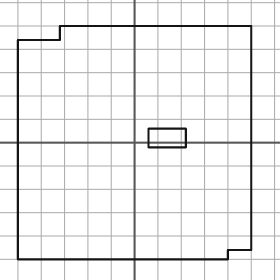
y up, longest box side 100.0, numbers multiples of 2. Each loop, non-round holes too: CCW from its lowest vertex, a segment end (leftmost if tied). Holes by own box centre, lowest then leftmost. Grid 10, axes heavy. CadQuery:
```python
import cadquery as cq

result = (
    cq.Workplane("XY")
    .moveTo(-50.0, -50.0)
    .lineTo(40.0, -50.0)
    .lineTo(40.0, -46.0)
    .lineTo(50.0, -46.0)
    .lineTo(50.0, 50.0)
    .lineTo(-32.0, 50.0)
    .lineTo(-32.0, 44.0)
    .lineTo(-50.0, 44.0)
    .close()
    .moveTo(6.0, -2.0)
    .lineTo(22.0, -2.0)
    .lineTo(22.0, 6.0)
    .lineTo(6.0, 6.0)
    .close()
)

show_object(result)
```